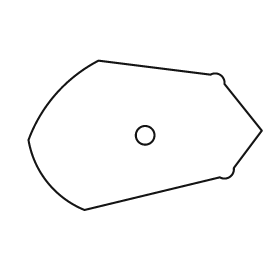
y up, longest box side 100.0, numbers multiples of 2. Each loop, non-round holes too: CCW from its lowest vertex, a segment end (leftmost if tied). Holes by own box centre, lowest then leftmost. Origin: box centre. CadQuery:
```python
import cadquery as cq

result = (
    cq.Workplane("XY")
    .moveTo(-26.0, -32.0)
    .lineTo(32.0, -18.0)
    .threePointArc((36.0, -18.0), (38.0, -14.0))
    .lineTo(50.0, 2.0)
    .lineTo(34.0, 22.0)
    .threePointArc((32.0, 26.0), (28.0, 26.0))
    .lineTo(-20.0, 32.0)
    .threePointArc((-38.0, 18.0), (-50.0, -2.0))
    .threePointArc((-42.0, -20.0), (-26.0, -32.0))
    .close()
    .moveTo(0.0, 0.0)
    .circle(4.0)
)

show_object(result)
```